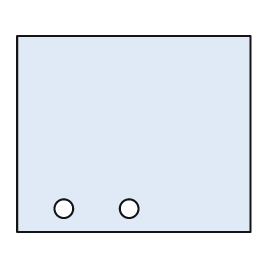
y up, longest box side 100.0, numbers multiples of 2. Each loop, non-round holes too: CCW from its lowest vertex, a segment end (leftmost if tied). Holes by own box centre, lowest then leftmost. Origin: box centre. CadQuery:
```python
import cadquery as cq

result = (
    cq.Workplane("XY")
    .moveTo(-50.0, -42.0)
    .lineTo(50.0, -42.0)
    .lineTo(50.0, 42.0)
    .lineTo(-50.0, 42.0)
    .close()
    .moveTo(-30.0, -32.0)
    .circle(4.0)
    .moveTo(-2.0, -32.0)
    .circle(4.0)
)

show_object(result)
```